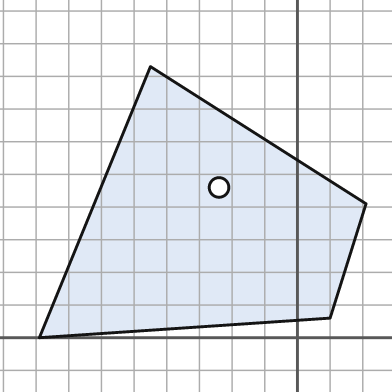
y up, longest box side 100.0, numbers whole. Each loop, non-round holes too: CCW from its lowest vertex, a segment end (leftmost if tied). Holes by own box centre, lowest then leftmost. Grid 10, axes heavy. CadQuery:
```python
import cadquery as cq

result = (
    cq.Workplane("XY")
    .moveTo(-79.0, 0.0)
    .lineTo(10.0, 6.0)
    .lineTo(21.0, 41.0)
    .lineTo(-45.0, 83.0)
    .close()
    .moveTo(-24.0, 46.0)
    .circle(3.0)
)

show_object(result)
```